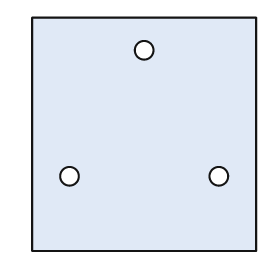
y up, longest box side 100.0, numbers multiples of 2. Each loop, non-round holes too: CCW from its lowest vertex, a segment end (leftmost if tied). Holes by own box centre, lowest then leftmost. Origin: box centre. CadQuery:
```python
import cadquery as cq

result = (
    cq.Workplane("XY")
    .moveTo(-48.0, -50.0)
    .lineTo(48.0, -50.0)
    .lineTo(48.0, 50.0)
    .lineTo(-48.0, 50.0)
    .close()
    .moveTo(-32.0, -18.0)
    .circle(4.0)
    .moveTo(32.0, -18.0)
    .circle(4.0)
    .moveTo(0.0, 36.0)
    .circle(4.0)
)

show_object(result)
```